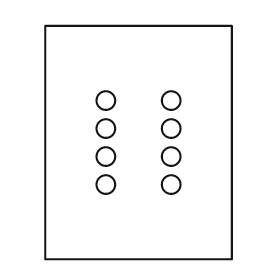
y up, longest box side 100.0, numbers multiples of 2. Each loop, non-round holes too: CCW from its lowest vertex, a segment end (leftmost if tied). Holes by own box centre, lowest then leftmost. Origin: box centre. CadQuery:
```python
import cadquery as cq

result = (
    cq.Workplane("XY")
    .moveTo(-40.0, -50.0)
    .lineTo(40.0, -50.0)
    .lineTo(40.0, 50.0)
    .lineTo(-40.0, 50.0)
    .close()
    .moveTo(-14.0, -18.0)
    .circle(4.0)
    .moveTo(14.0, -18.0)
    .circle(4.0)
    .moveTo(-14.0, -6.0)
    .circle(4.0)
    .moveTo(14.0, -6.0)
    .circle(4.0)
    .moveTo(-14.0, 6.0)
    .circle(4.0)
    .moveTo(14.0, 6.0)
    .circle(4.0)
    .moveTo(-14.0, 18.0)
    .circle(4.0)
    .moveTo(14.0, 18.0)
    .circle(4.0)
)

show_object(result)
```